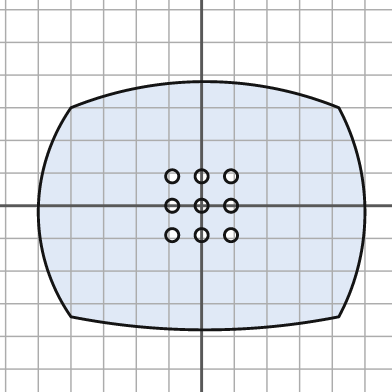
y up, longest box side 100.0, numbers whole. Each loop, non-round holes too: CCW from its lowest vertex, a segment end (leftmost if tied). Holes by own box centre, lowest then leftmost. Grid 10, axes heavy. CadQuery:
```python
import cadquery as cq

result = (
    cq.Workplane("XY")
    .moveTo(-40.0, -34.0)
    .threePointArc((1.0, -38.0), (42.0, -34.0))
    .threePointArc((50.0, -2.0), (42.0, 30.0))
    .threePointArc((1.0, 38.0), (-40.0, 30.0))
    .threePointArc((-50.0, -2.0), (-40.0, -34.0))
    .close()
    .moveTo(-9.0, -9.0)
    .circle(2.0)
    .moveTo(0.0, -9.0)
    .circle(2.0)
    .moveTo(9.0, -9.0)
    .circle(2.0)
    .moveTo(-9.0, 0.0)
    .circle(2.0)
    .moveTo(0.0, 0.0)
    .circle(2.0)
    .moveTo(9.0, 0.0)
    .circle(2.0)
    .moveTo(-9.0, 9.0)
    .circle(2.0)
    .moveTo(0.0, 9.0)
    .circle(2.0)
    .moveTo(9.0, 9.0)
    .circle(2.0)
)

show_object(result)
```